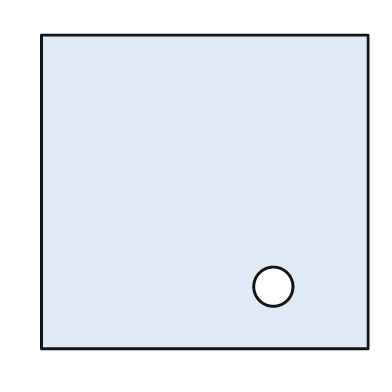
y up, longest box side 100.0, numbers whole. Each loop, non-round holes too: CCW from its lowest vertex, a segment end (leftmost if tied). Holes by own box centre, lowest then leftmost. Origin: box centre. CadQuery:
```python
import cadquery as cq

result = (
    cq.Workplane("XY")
    .moveTo(-50.0, -48.0)
    .lineTo(50.0, -48.0)
    .lineTo(50.0, 48.0)
    .lineTo(-50.0, 48.0)
    .close()
    .moveTo(21.0, -29.0)
    .circle(6.0)
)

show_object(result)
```